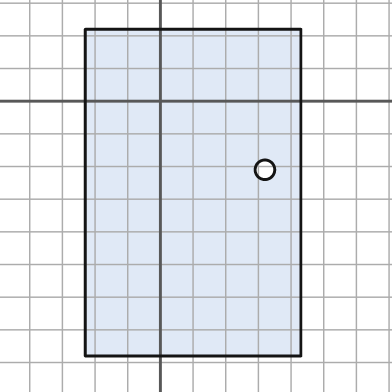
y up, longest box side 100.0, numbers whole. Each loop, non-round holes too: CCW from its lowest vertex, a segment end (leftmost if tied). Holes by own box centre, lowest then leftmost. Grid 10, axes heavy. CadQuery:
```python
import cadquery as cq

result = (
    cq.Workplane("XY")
    .moveTo(-23.0, -78.0)
    .lineTo(43.0, -78.0)
    .lineTo(43.0, 22.0)
    .lineTo(-23.0, 22.0)
    .close()
    .moveTo(32.0, -21.0)
    .circle(3.0)
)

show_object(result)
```